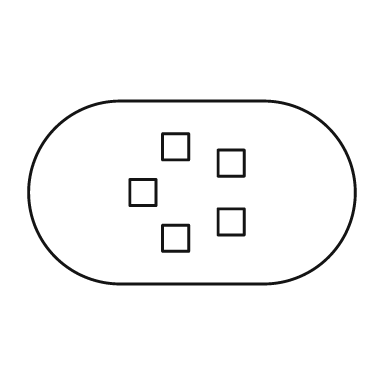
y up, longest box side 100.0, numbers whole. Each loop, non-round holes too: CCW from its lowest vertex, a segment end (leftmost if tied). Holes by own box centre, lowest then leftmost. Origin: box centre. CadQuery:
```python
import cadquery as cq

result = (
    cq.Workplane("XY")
    .moveTo(-22.0, -28.0)
    .lineTo(22.0, -28.0)
    .threePointArc((50.0, 0.0), (22.0, 28.0))
    .lineTo(-22.0, 28.0)
    .threePointArc((-50.0, 0.0), (-22.0, -28.0))
    .close()
    .moveTo(-9.0, -18.0)
    .lineTo(-1.0, -18.0)
    .lineTo(-1.0, -10.0)
    .lineTo(-9.0, -10.0)
    .close()
    .moveTo(8.0, -13.0)
    .lineTo(16.0, -13.0)
    .lineTo(16.0, -5.0)
    .lineTo(8.0, -5.0)
    .close()
    .moveTo(-19.0, -4.0)
    .lineTo(-11.0, -4.0)
    .lineTo(-11.0, 4.0)
    .lineTo(-19.0, 4.0)
    .close()
    .moveTo(8.0, 5.0)
    .lineTo(16.0, 5.0)
    .lineTo(16.0, 13.0)
    .lineTo(8.0, 13.0)
    .close()
    .moveTo(-9.0, 10.0)
    .lineTo(-1.0, 10.0)
    .lineTo(-1.0, 18.0)
    .lineTo(-9.0, 18.0)
    .close()
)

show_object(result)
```